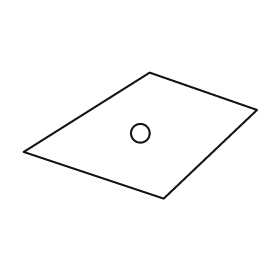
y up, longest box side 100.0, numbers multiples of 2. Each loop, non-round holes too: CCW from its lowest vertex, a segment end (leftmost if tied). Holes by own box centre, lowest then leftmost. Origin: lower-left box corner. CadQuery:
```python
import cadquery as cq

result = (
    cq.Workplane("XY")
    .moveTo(60.0, 0.0)
    .lineTo(100.0, 38.0)
    .lineTo(54.0, 54.0)
    .lineTo(0.0, 20.0)
    .close()
    .moveTo(50.0, 28.0)
    .circle(4.0)
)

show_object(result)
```